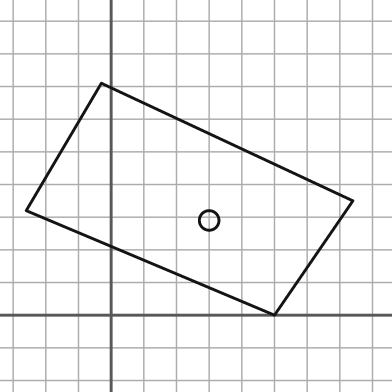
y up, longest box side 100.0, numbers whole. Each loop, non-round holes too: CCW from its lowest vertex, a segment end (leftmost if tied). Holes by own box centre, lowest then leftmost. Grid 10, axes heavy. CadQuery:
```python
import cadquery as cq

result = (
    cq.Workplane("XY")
    .moveTo(50.0, 0.0)
    .lineTo(74.0, 35.0)
    .lineTo(-3.0, 71.0)
    .lineTo(-26.0, 32.0)
    .close()
    .moveTo(30.0, 29.0)
    .circle(3.0)
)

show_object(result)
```